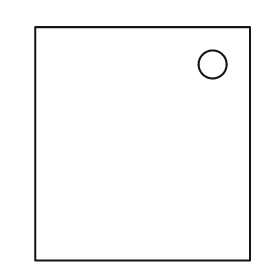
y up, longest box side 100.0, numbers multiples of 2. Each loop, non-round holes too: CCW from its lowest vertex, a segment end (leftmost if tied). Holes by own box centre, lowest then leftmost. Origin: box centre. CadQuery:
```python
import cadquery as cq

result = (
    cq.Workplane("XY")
    .moveTo(-46.0, -50.0)
    .lineTo(46.0, -50.0)
    .lineTo(46.0, 50.0)
    .lineTo(-46.0, 50.0)
    .close()
    .moveTo(30.0, 34.0)
    .circle(6.0)
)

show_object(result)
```